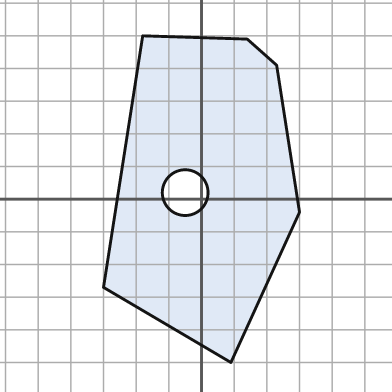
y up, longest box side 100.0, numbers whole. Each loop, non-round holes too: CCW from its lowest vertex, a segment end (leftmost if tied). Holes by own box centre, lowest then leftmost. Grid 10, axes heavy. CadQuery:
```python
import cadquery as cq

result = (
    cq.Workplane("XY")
    .moveTo(9.0, -50.0)
    .lineTo(30.0, -4.0)
    .lineTo(23.0, 41.0)
    .lineTo(14.0, 49.0)
    .lineTo(-18.0, 50.0)
    .lineTo(-30.0, -27.0)
    .close()
    .moveTo(-5.0, 2.0)
    .circle(7.0)
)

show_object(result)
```